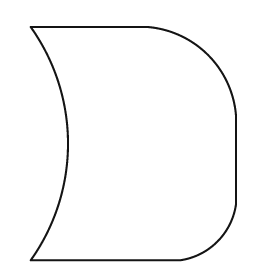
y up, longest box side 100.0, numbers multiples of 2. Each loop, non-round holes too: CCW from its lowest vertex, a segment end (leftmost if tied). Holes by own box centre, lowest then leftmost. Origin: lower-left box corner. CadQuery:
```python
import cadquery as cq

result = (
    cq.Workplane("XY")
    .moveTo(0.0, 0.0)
    .lineTo(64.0, 0.0)
    .threePointArc((80.0, 8.0), (88.0, 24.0))
    .lineTo(88.0, 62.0)
    .threePointArc((76.0, 88.0), (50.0, 100.0))
    .lineTo(0.0, 100.0)
    .threePointArc((16.0, 50.0), (0.0, 0.0))
    .close()
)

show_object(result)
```